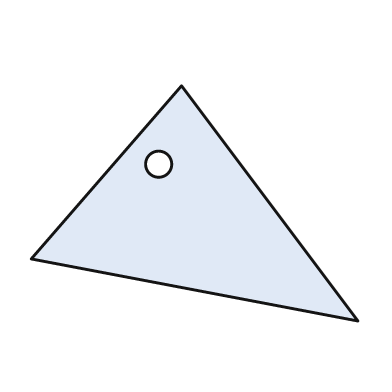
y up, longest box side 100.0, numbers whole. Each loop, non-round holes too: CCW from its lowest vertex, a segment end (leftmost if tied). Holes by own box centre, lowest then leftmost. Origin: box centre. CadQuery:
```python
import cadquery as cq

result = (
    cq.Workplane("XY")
    .moveTo(50.0, -36.0)
    .lineTo(-4.0, 36.0)
    .lineTo(-50.0, -17.0)
    .close()
    .moveTo(-11.0, 12.0)
    .circle(4.0)
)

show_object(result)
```